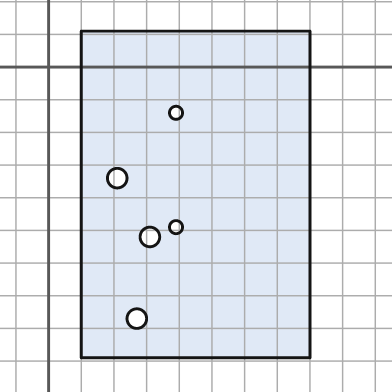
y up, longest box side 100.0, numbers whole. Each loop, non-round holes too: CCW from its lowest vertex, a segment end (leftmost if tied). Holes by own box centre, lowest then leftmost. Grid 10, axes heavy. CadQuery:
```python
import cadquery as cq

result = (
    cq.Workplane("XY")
    .moveTo(10.0, -89.0)
    .lineTo(80.0, -89.0)
    .lineTo(80.0, 11.0)
    .lineTo(10.0, 11.0)
    .close()
    .moveTo(27.0, -77.0)
    .circle(3.0)
    .moveTo(31.0, -52.0)
    .circle(3.0)
    .moveTo(39.0, -49.0)
    .circle(2.0)
    .moveTo(21.0, -34.0)
    .circle(3.0)
    .moveTo(39.0, -14.0)
    .circle(2.0)
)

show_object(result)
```